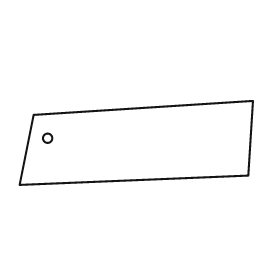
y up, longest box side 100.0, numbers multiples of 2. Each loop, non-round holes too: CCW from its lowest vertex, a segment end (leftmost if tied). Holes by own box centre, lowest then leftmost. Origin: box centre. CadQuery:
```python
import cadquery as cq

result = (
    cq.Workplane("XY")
    .moveTo(-50.0, -18.0)
    .lineTo(48.0, -14.0)
    .lineTo(50.0, 18.0)
    .lineTo(-44.0, 12.0)
    .close()
    .moveTo(-38.0, 2.0)
    .circle(2.0)
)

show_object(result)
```